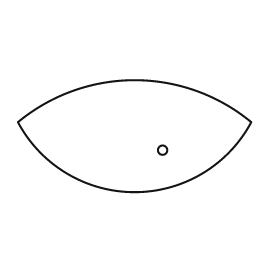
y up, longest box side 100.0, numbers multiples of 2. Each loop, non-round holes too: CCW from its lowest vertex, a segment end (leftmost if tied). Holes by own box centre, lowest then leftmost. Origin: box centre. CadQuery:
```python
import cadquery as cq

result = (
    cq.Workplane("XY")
    .moveTo(-50.0, 6.0)
    .threePointArc((0.0, -24.0), (50.0, 6.0))
    .threePointArc((0.0, 24.0), (-50.0, 6.0))
    .close()
    .moveTo(12.0, -6.0)
    .circle(2.0)
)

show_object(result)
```